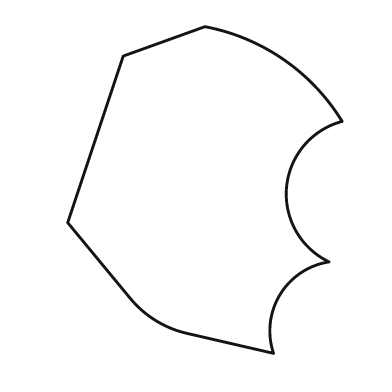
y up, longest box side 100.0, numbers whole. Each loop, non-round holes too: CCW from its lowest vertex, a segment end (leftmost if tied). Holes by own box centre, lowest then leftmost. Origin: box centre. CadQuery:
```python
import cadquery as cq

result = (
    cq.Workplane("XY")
    .moveTo(21.0, -50.0)
    .threePointArc((23.0, -32.0), (38.0, -22.0))
    .threePointArc((25.0, 1.0), (42.0, 21.0))
    .threePointArc((24.0, 40.0), (0.0, 50.0))
    .lineTo(-25.0, 41.0)
    .lineTo(-42.0, -10.0)
    .lineTo(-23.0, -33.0)
    .threePointArc((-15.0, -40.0), (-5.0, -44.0))
    .close()
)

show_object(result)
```